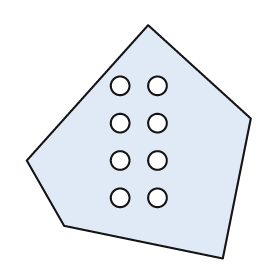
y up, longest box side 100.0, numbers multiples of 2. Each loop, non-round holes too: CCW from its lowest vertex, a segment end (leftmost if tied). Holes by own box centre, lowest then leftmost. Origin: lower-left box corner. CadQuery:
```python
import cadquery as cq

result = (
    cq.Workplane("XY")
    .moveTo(84.0, 0.0)
    .lineTo(96.0, 60.0)
    .lineTo(52.0, 100.0)
    .lineTo(0.0, 42.0)
    .lineTo(16.0, 14.0)
    .close()
    .moveTo(40.0, 26.0)
    .circle(4.0)
    .moveTo(56.0, 26.0)
    .circle(4.0)
    .moveTo(40.0, 42.0)
    .circle(4.0)
    .moveTo(56.0, 42.0)
    .circle(4.0)
    .moveTo(40.0, 58.0)
    .circle(4.0)
    .moveTo(56.0, 58.0)
    .circle(4.0)
    .moveTo(40.0, 74.0)
    .circle(4.0)
    .moveTo(56.0, 74.0)
    .circle(4.0)
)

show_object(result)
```